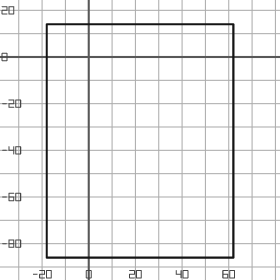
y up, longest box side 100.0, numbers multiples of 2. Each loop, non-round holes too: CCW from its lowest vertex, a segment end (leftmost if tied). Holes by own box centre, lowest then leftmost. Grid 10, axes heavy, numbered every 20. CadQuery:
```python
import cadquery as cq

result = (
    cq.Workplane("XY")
    .moveTo(-18.0, -86.0)
    .lineTo(62.0, -86.0)
    .lineTo(62.0, 14.0)
    .lineTo(-18.0, 14.0)
    .close()
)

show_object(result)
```